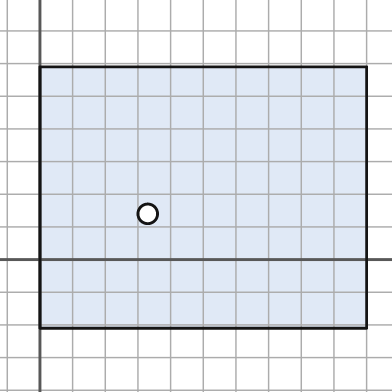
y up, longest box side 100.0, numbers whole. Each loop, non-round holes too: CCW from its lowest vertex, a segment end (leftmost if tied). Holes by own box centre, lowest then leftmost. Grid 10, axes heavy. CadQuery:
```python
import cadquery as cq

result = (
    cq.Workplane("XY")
    .moveTo(0.0, -21.0)
    .lineTo(100.0, -21.0)
    .lineTo(100.0, 59.0)
    .lineTo(0.0, 59.0)
    .close()
    .moveTo(33.0, 14.0)
    .circle(3.0)
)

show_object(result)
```